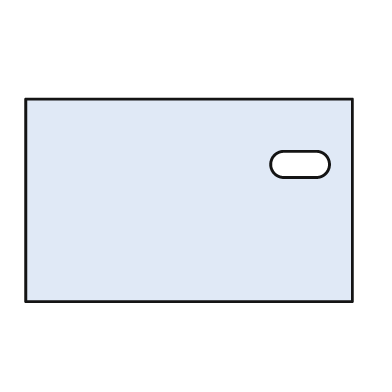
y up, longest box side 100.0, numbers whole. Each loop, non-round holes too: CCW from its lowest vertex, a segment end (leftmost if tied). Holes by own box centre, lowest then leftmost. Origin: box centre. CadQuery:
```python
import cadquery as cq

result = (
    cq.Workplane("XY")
    .moveTo(-50.0, -31.0)
    .lineTo(50.0, -31.0)
    .lineTo(50.0, 31.0)
    .lineTo(-50.0, 31.0)
    .close()
    .moveTo(29.0, 7.0)
    .lineTo(39.0, 7.0)
    .threePointArc((43.0, 11.0), (39.0, 15.0))
    .lineTo(29.0, 15.0)
    .threePointArc((25.0, 11.0), (29.0, 7.0))
    .close()
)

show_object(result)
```